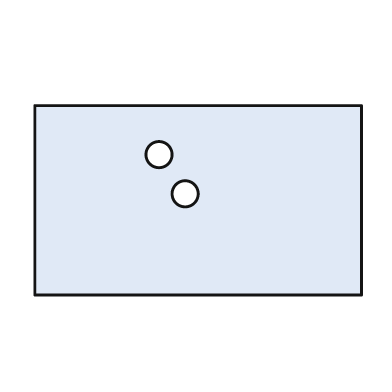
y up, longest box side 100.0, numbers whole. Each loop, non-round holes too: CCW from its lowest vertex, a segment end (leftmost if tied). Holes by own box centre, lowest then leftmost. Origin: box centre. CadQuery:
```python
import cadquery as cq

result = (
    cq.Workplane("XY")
    .moveTo(-50.0, -29.0)
    .lineTo(50.0, -29.0)
    .lineTo(50.0, 29.0)
    .lineTo(-50.0, 29.0)
    .close()
    .moveTo(-4.0, 2.0)
    .circle(4.0)
    .moveTo(-12.0, 14.0)
    .circle(4.0)
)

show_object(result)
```